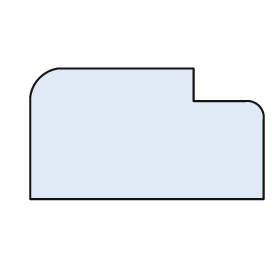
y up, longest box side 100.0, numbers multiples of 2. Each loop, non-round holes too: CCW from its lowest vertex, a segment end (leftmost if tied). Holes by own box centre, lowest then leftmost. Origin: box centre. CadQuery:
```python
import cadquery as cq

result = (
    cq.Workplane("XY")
    .moveTo(-50.0, -28.0)
    .lineTo(50.0, -28.0)
    .lineTo(50.0, 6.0)
    .threePointArc((48.0, 12.0), (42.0, 14.0))
    .lineTo(20.0, 14.0)
    .lineTo(20.0, 28.0)
    .lineTo(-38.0, 28.0)
    .threePointArc((-46.0, 24.0), (-50.0, 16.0))
    .close()
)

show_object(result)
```